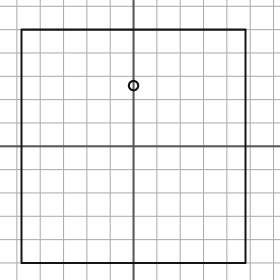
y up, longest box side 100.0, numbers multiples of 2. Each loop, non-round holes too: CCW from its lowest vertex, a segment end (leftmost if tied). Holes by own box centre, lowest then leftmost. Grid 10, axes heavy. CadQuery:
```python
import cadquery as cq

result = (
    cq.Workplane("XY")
    .moveTo(-48.0, -50.0)
    .lineTo(48.0, -50.0)
    .lineTo(48.0, 50.0)
    .lineTo(-48.0, 50.0)
    .close()
    .moveTo(0.0, 26.0)
    .circle(2.0)
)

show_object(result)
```